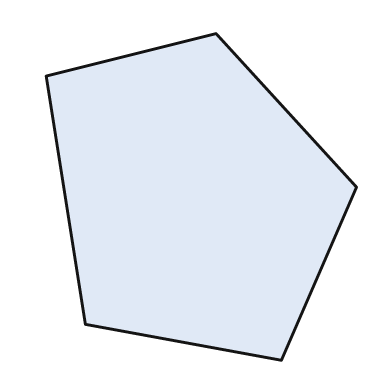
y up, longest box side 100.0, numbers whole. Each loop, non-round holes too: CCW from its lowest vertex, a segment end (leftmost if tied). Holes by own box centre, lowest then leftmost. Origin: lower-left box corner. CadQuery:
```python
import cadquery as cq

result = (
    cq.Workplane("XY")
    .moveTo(72.0, 0.0)
    .lineTo(95.0, 53.0)
    .lineTo(52.0, 100.0)
    .lineTo(0.0, 87.0)
    .lineTo(12.0, 11.0)
    .close()
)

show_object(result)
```